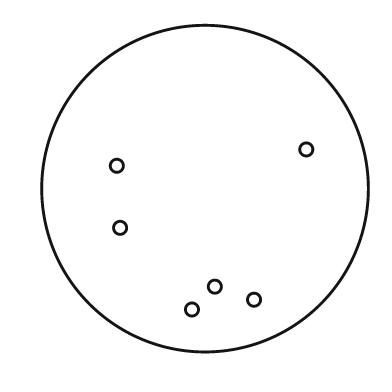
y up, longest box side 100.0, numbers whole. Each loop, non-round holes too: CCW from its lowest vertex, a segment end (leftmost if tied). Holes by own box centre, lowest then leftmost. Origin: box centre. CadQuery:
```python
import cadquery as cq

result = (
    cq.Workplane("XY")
    .moveTo(0.0, 0.0)
    .circle(50.0)
    .moveTo(-4.0, -37.0)
    .circle(2.0)
    .moveTo(15.0, -34.0)
    .circle(2.0)
    .moveTo(3.0, -30.0)
    .circle(2.0)
    .moveTo(-26.0, -12.0)
    .circle(2.0)
    .moveTo(-27.0, 7.0)
    .circle(2.0)
    .moveTo(31.0, 12.0)
    .circle(2.0)
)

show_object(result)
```